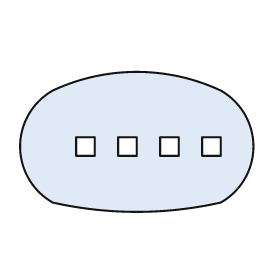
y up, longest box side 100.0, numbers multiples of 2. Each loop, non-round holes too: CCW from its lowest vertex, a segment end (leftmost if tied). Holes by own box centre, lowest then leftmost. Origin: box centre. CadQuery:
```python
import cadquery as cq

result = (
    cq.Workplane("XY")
    .moveTo(-36.0, -26.0)
    .threePointArc((0.0, -30.0), (36.0, -26.0))
    .threePointArc((50.0, -2.0), (36.0, 22.0))
    .threePointArc((0.0, 30.0), (-36.0, 22.0))
    .threePointArc((-50.0, -2.0), (-36.0, -26.0))
    .close()
    .moveTo(-26.0, -6.0)
    .lineTo(-18.0, -6.0)
    .lineTo(-18.0, 2.0)
    .lineTo(-26.0, 2.0)
    .close()
    .moveTo(-8.0, -6.0)
    .lineTo(0.0, -6.0)
    .lineTo(0.0, 2.0)
    .lineTo(-8.0, 2.0)
    .close()
    .moveTo(10.0, -6.0)
    .lineTo(18.0, -6.0)
    .lineTo(18.0, 2.0)
    .lineTo(10.0, 2.0)
    .close()
    .moveTo(28.0, -6.0)
    .lineTo(36.0, -6.0)
    .lineTo(36.0, 2.0)
    .lineTo(28.0, 2.0)
    .close()
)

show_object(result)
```